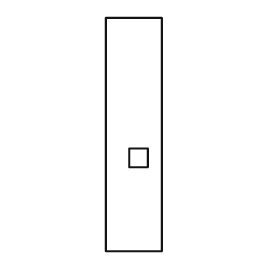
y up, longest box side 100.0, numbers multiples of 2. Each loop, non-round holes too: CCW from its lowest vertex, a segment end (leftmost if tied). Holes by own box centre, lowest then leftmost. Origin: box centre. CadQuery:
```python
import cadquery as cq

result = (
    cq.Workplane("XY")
    .moveTo(-12.0, -50.0)
    .lineTo(12.0, -50.0)
    .lineTo(12.0, 50.0)
    .lineTo(-12.0, 50.0)
    .close()
    .moveTo(-2.0, -14.0)
    .lineTo(6.0, -14.0)
    .lineTo(6.0, -6.0)
    .lineTo(-2.0, -6.0)
    .close()
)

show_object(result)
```